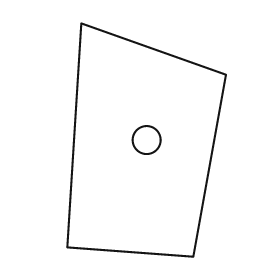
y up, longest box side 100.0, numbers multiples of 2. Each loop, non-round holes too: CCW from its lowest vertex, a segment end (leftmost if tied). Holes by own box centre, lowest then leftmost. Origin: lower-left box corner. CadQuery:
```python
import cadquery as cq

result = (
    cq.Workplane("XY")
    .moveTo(54.0, 0.0)
    .lineTo(68.0, 78.0)
    .lineTo(6.0, 100.0)
    .lineTo(0.0, 4.0)
    .close()
    .moveTo(34.0, 50.0)
    .circle(6.0)
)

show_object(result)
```